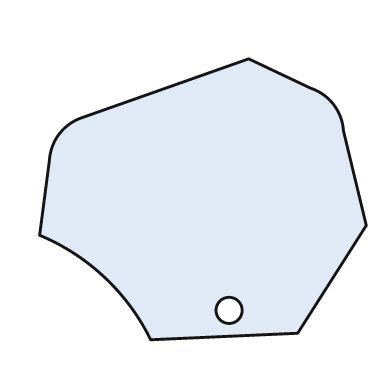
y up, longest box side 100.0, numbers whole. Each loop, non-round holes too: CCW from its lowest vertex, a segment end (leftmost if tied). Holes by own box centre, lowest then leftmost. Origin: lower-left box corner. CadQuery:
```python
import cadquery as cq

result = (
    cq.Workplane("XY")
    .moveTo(34.0, 0.0)
    .lineTo(79.0, 2.0)
    .lineTo(100.0, 35.0)
    .lineTo(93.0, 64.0)
    .threePointArc((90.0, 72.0), (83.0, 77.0))
    .lineTo(64.0, 86.0)
    .lineTo(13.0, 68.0)
    .threePointArc((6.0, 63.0), (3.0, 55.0))
    .lineTo(0.0, 32.0)
    .threePointArc((20.0, 19.0), (34.0, 0.0))
    .close()
    .moveTo(58.0, 9.0)
    .circle(4.0)
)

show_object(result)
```